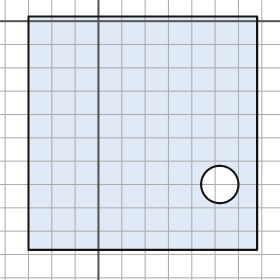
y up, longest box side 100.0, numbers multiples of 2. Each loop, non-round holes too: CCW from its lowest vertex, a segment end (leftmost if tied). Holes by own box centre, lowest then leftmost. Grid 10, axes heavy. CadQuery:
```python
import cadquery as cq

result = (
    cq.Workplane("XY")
    .moveTo(-30.0, -98.0)
    .lineTo(68.0, -98.0)
    .lineTo(68.0, 2.0)
    .lineTo(-30.0, 2.0)
    .close()
    .moveTo(52.0, -70.0)
    .circle(8.0)
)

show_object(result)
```